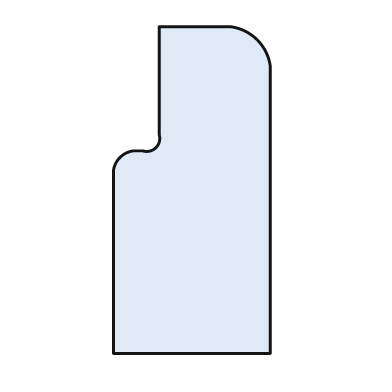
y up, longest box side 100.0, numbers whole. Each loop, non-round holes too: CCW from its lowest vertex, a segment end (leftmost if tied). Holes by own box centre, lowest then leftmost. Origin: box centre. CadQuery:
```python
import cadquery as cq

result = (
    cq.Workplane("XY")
    .moveTo(-24.0, -50.0)
    .lineTo(24.0, -50.0)
    .lineTo(24.0, 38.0)
    .threePointArc((20.0, 46.0), (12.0, 50.0))
    .lineTo(-10.0, 50.0)
    .lineTo(-10.0, 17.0)
    .threePointArc((-11.0, 13.0), (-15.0, 12.0))
    .lineTo(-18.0, 12.0)
    .threePointArc((-22.0, 10.0), (-24.0, 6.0))
    .close()
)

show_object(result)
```